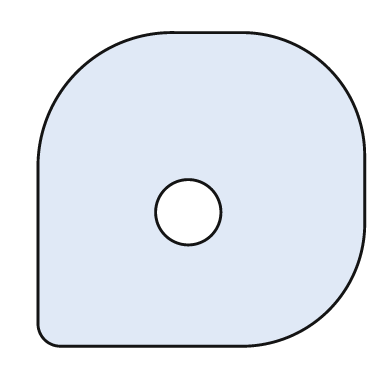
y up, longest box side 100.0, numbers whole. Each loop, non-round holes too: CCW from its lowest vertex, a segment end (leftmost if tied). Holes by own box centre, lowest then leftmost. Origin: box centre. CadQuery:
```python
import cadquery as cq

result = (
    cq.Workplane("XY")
    .moveTo(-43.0, -48.0)
    .lineTo(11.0, -48.0)
    .threePointArc((39.0, -37.0), (50.0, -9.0))
    .lineTo(50.0, 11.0)
    .threePointArc((39.0, 37.0), (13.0, 48.0))
    .lineTo(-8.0, 48.0)
    .threePointArc((-38.0, 36.0), (-50.0, 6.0))
    .lineTo(-50.0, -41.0)
    .threePointArc((-48.0, -46.0), (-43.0, -48.0))
    .close()
    .moveTo(-4.0, -7.0)
    .circle(10.0)
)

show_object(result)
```